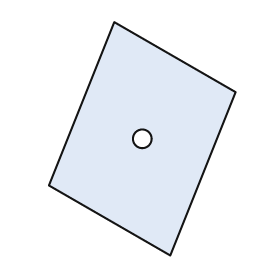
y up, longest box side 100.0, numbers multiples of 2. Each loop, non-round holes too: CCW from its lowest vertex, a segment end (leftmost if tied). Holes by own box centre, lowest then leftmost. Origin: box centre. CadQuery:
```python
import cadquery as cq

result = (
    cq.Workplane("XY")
    .moveTo(12.0, -50.0)
    .lineTo(40.0, 20.0)
    .lineTo(-12.0, 50.0)
    .lineTo(-40.0, -20.0)
    .close()
    .moveTo(0.0, 0.0)
    .circle(4.0)
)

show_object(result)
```